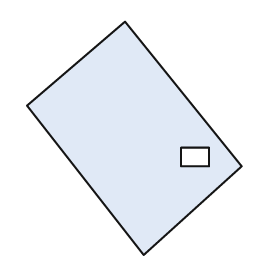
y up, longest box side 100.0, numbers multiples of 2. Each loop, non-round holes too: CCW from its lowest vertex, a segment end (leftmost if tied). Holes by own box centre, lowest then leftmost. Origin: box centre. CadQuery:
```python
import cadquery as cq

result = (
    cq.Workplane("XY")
    .moveTo(4.0, -50.0)
    .lineTo(46.0, -12.0)
    .lineTo(-4.0, 50.0)
    .lineTo(-46.0, 14.0)
    .close()
    .moveTo(20.0, -12.0)
    .lineTo(32.0, -12.0)
    .lineTo(32.0, -4.0)
    .lineTo(20.0, -4.0)
    .close()
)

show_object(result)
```